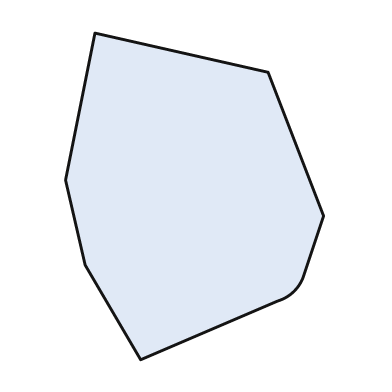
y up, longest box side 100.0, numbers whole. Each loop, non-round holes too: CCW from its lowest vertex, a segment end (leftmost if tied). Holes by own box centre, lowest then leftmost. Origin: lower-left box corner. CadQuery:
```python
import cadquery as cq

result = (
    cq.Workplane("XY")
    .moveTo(23.0, 0.0)
    .lineTo(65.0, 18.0)
    .threePointArc((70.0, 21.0), (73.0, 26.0))
    .lineTo(79.0, 44.0)
    .lineTo(62.0, 88.0)
    .lineTo(9.0, 100.0)
    .lineTo(0.0, 55.0)
    .lineTo(6.0, 29.0)
    .close()
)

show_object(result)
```